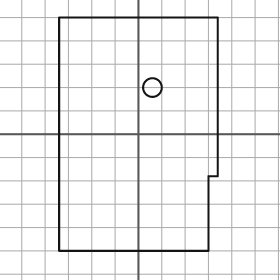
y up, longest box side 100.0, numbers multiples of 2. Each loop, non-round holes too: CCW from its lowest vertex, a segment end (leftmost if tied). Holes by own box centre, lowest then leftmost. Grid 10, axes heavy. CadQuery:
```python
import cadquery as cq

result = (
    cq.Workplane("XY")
    .moveTo(-34.0, -50.0)
    .lineTo(30.0, -50.0)
    .lineTo(30.0, -18.0)
    .lineTo(34.0, -18.0)
    .lineTo(34.0, 50.0)
    .lineTo(-34.0, 50.0)
    .close()
    .moveTo(6.0, 20.0)
    .circle(4.0)
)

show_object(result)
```